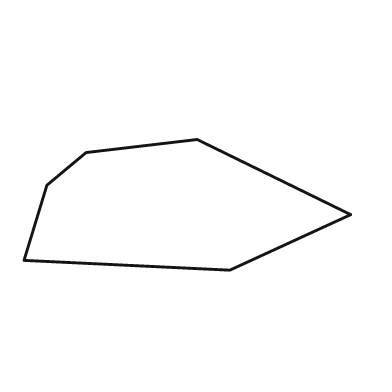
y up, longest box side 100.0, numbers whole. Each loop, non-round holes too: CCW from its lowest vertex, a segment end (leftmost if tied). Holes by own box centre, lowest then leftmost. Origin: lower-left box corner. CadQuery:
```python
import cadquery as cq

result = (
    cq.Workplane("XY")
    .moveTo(63.0, 0.0)
    .lineTo(100.0, 17.0)
    .lineTo(53.0, 40.0)
    .lineTo(19.0, 36.0)
    .lineTo(7.0, 26.0)
    .lineTo(0.0, 3.0)
    .close()
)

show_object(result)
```